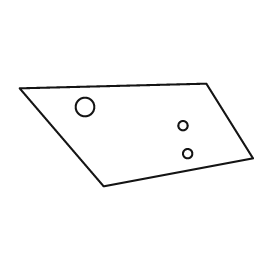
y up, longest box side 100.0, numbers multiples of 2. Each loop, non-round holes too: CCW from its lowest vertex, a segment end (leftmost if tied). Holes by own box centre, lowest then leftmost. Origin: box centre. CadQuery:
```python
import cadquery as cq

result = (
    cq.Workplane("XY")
    .moveTo(-14.0, -22.0)
    .lineTo(50.0, -10.0)
    .lineTo(30.0, 22.0)
    .lineTo(-50.0, 20.0)
    .close()
    .moveTo(22.0, -8.0)
    .circle(2.0)
    .moveTo(20.0, 4.0)
    .circle(2.0)
    .moveTo(-22.0, 12.0)
    .circle(4.0)
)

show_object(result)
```